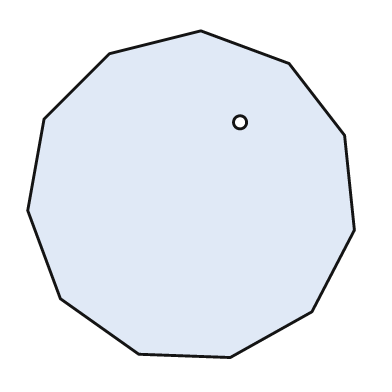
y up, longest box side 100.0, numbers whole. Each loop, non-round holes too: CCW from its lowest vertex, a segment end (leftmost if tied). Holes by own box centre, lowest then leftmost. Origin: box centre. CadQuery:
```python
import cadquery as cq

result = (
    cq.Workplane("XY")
    .moveTo(12.0, -50.0)
    .lineTo(37.0, -36.0)
    .lineTo(50.0, -11.0)
    .lineTo(47.0, 18.0)
    .lineTo(30.0, 40.0)
    .lineTo(3.0, 50.0)
    .lineTo(-25.0, 43.0)
    .lineTo(-45.0, 23.0)
    .lineTo(-50.0, -5.0)
    .lineTo(-40.0, -32.0)
    .lineTo(-16.0, -49.0)
    .close()
    .moveTo(15.0, 22.0)
    .circle(2.0)
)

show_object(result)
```